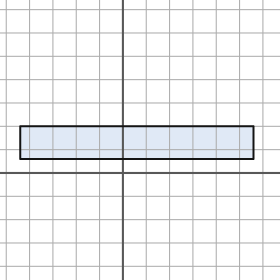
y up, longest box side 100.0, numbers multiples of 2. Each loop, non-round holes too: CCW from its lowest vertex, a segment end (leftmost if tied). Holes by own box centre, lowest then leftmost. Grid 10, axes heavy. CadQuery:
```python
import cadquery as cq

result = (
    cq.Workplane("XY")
    .moveTo(-44.0, 6.0)
    .lineTo(56.0, 6.0)
    .lineTo(56.0, 20.0)
    .lineTo(-44.0, 20.0)
    .close()
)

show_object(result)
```